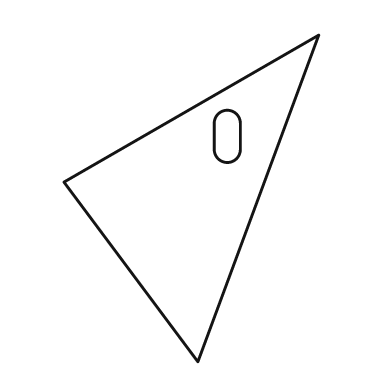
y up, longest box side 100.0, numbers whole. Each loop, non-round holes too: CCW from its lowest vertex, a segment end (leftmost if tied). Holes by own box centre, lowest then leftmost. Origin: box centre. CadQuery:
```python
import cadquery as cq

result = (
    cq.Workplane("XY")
    .moveTo(2.0, -50.0)
    .lineTo(39.0, 50.0)
    .lineTo(-39.0, 5.0)
    .close()
    .moveTo(7.0, 15.0)
    .threePointArc((11.0, 11.0), (15.0, 15.0))
    .lineTo(15.0, 23.0)
    .threePointArc((11.0, 27.0), (7.0, 23.0))
    .close()
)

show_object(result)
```